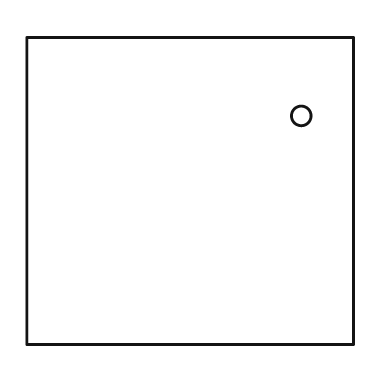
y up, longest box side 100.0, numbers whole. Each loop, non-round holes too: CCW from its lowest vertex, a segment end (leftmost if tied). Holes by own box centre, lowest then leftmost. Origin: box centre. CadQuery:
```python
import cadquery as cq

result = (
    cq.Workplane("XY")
    .moveTo(-50.0, -47.0)
    .lineTo(50.0, -47.0)
    .lineTo(50.0, 47.0)
    .lineTo(-50.0, 47.0)
    .close()
    .moveTo(34.0, 23.0)
    .circle(3.0)
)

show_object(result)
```